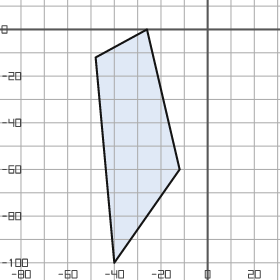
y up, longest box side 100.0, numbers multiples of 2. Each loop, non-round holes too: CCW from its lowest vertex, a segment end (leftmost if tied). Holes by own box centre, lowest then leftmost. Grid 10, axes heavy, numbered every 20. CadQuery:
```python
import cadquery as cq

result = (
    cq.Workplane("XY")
    .moveTo(-40.0, -100.0)
    .lineTo(-12.0, -60.0)
    .lineTo(-26.0, 0.0)
    .lineTo(-48.0, -12.0)
    .close()
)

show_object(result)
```